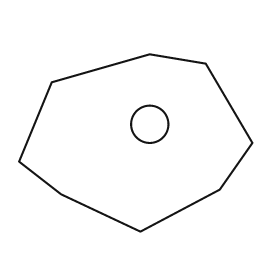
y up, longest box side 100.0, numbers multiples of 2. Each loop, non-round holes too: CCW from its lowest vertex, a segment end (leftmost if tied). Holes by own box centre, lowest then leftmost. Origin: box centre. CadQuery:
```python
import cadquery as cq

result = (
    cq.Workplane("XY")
    .moveTo(2.0, -38.0)
    .lineTo(36.0, -20.0)
    .lineTo(50.0, 0.0)
    .lineTo(30.0, 34.0)
    .lineTo(6.0, 38.0)
    .lineTo(-36.0, 26.0)
    .lineTo(-50.0, -8.0)
    .lineTo(-32.0, -22.0)
    .close()
    .moveTo(6.0, 8.0)
    .circle(8.0)
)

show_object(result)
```